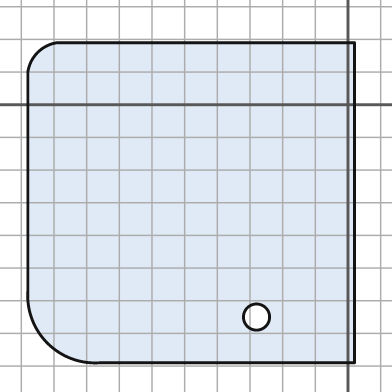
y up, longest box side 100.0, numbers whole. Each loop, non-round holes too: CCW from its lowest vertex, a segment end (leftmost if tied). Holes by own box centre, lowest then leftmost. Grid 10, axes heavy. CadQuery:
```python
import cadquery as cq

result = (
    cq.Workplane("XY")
    .moveTo(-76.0, -79.0)
    .lineTo(2.0, -79.0)
    .lineTo(2.0, 19.0)
    .lineTo(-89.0, 19.0)
    .threePointArc((-95.0, 16.0), (-98.0, 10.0))
    .lineTo(-98.0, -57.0)
    .threePointArc((-92.0, -73.0), (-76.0, -79.0))
    .close()
    .moveTo(-28.0, -65.0)
    .circle(4.0)
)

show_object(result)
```